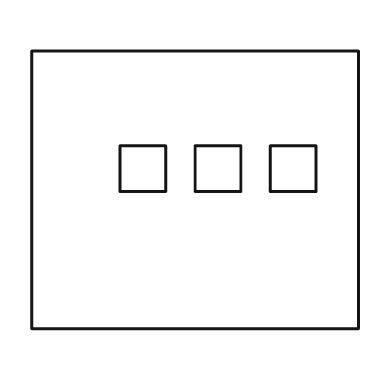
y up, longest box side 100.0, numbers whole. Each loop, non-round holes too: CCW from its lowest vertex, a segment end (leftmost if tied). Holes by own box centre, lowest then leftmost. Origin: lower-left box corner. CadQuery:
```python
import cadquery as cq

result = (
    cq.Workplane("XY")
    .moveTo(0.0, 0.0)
    .lineTo(100.0, 0.0)
    .lineTo(100.0, 85.0)
    .lineTo(0.0, 85.0)
    .close()
    .moveTo(27.0, 42.0)
    .lineTo(41.0, 42.0)
    .lineTo(41.0, 56.0)
    .lineTo(27.0, 56.0)
    .close()
    .moveTo(50.0, 42.0)
    .lineTo(64.0, 42.0)
    .lineTo(64.0, 56.0)
    .lineTo(50.0, 56.0)
    .close()
    .moveTo(73.0, 42.0)
    .lineTo(87.0, 42.0)
    .lineTo(87.0, 56.0)
    .lineTo(73.0, 56.0)
    .close()
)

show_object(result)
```